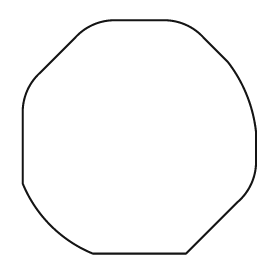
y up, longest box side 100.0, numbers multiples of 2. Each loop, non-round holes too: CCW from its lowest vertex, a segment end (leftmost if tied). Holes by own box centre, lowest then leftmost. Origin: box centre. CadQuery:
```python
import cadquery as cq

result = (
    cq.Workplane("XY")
    .moveTo(-20.0, -50.0)
    .lineTo(20.0, -50.0)
    .lineTo(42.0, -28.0)
    .threePointArc((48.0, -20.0), (50.0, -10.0))
    .lineTo(50.0, 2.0)
    .threePointArc((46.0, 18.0), (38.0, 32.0))
    .lineTo(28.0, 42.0)
    .threePointArc((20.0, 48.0), (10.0, 50.0))
    .lineTo(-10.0, 50.0)
    .threePointArc((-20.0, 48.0), (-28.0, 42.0))
    .lineTo(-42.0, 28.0)
    .threePointArc((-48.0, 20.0), (-50.0, 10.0))
    .lineTo(-50.0, -20.0)
    .threePointArc((-38.0, -38.0), (-20.0, -50.0))
    .close()
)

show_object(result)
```